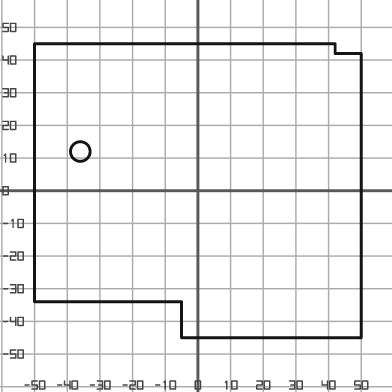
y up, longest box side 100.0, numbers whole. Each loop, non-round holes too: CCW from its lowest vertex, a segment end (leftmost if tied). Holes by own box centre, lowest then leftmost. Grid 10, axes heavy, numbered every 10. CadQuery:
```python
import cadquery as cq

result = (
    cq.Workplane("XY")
    .moveTo(-5.0, -45.0)
    .lineTo(50.0, -45.0)
    .lineTo(50.0, 42.0)
    .lineTo(42.0, 42.0)
    .lineTo(42.0, 45.0)
    .lineTo(-50.0, 45.0)
    .lineTo(-50.0, -34.0)
    .lineTo(-5.0, -34.0)
    .close()
    .moveTo(-36.0, 12.0)
    .circle(3.0)
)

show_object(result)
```